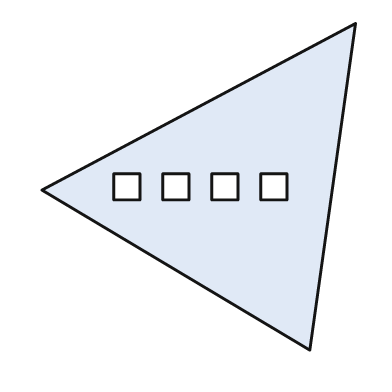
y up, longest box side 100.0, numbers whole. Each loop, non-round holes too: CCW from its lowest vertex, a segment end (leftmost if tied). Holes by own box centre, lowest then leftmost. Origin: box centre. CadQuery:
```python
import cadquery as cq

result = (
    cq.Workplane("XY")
    .moveTo(34.0, -50.0)
    .lineTo(48.0, 50.0)
    .lineTo(-48.0, -1.0)
    .close()
    .moveTo(-26.0, -4.0)
    .lineTo(-18.0, -4.0)
    .lineTo(-18.0, 4.0)
    .lineTo(-26.0, 4.0)
    .close()
    .moveTo(-11.0, -4.0)
    .lineTo(-3.0, -4.0)
    .lineTo(-3.0, 4.0)
    .lineTo(-11.0, 4.0)
    .close()
    .moveTo(4.0, -4.0)
    .lineTo(12.0, -4.0)
    .lineTo(12.0, 4.0)
    .lineTo(4.0, 4.0)
    .close()
    .moveTo(19.0, -4.0)
    .lineTo(27.0, -4.0)
    .lineTo(27.0, 4.0)
    .lineTo(19.0, 4.0)
    .close()
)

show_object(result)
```